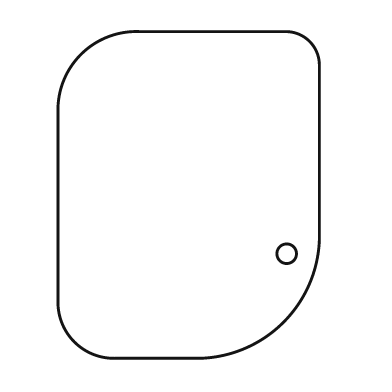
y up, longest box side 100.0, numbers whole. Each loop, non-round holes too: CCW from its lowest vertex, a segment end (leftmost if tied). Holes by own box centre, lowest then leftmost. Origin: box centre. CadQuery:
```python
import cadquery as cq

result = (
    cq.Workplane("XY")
    .moveTo(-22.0, -50.0)
    .lineTo(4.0, -50.0)
    .threePointArc((29.0, -39.0), (40.0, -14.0))
    .lineTo(40.0, 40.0)
    .threePointArc((37.0, 47.0), (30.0, 50.0))
    .lineTo(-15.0, 50.0)
    .threePointArc((-33.0, 43.0), (-40.0, 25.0))
    .lineTo(-40.0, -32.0)
    .threePointArc((-35.0, -45.0), (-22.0, -50.0))
    .close()
    .moveTo(30.0, -18.0)
    .circle(3.0)
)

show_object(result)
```